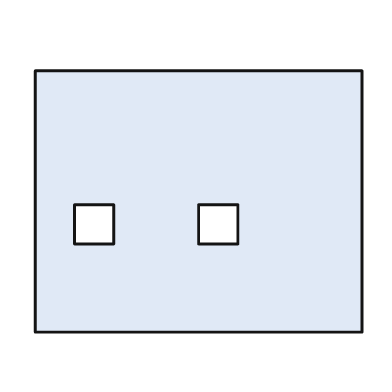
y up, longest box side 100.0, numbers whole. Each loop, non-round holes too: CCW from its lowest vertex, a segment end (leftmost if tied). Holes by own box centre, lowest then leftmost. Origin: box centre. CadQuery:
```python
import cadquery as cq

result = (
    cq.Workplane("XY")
    .moveTo(-50.0, -40.0)
    .lineTo(50.0, -40.0)
    .lineTo(50.0, 40.0)
    .lineTo(-50.0, 40.0)
    .close()
    .moveTo(-38.0, -13.0)
    .lineTo(-26.0, -13.0)
    .lineTo(-26.0, -1.0)
    .lineTo(-38.0, -1.0)
    .close()
    .moveTo(0.0, -13.0)
    .lineTo(12.0, -13.0)
    .lineTo(12.0, -1.0)
    .lineTo(0.0, -1.0)
    .close()
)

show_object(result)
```